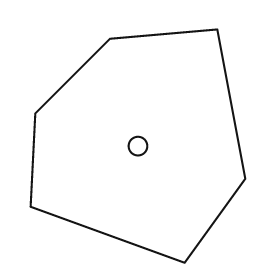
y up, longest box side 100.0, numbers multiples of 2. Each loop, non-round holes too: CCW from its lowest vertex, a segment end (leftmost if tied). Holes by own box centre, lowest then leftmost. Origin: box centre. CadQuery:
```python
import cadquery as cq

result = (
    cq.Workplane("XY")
    .moveTo(20.0, -50.0)
    .lineTo(46.0, -14.0)
    .lineTo(34.0, 50.0)
    .lineTo(-12.0, 46.0)
    .lineTo(-44.0, 14.0)
    .lineTo(-46.0, -26.0)
    .close()
    .moveTo(0.0, 0.0)
    .circle(4.0)
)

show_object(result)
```